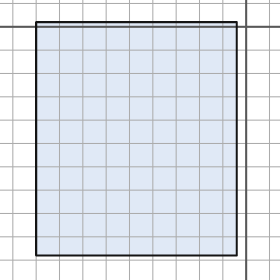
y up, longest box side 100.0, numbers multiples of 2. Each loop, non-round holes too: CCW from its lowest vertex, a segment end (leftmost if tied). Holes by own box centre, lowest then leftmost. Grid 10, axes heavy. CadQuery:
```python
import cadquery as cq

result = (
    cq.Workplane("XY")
    .moveTo(-90.0, -98.0)
    .lineTo(-4.0, -98.0)
    .lineTo(-4.0, 2.0)
    .lineTo(-90.0, 2.0)
    .close()
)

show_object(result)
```